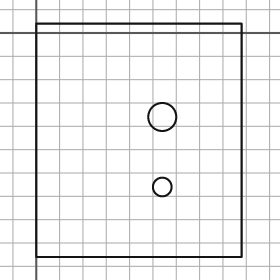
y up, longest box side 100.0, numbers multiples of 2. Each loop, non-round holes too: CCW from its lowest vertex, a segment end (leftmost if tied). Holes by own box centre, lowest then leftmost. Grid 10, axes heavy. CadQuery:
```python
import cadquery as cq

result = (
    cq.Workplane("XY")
    .moveTo(0.0, -96.0)
    .lineTo(88.0, -96.0)
    .lineTo(88.0, 4.0)
    .lineTo(0.0, 4.0)
    .close()
    .moveTo(54.0, -66.0)
    .circle(4.0)
    .moveTo(54.0, -36.0)
    .circle(6.0)
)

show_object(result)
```